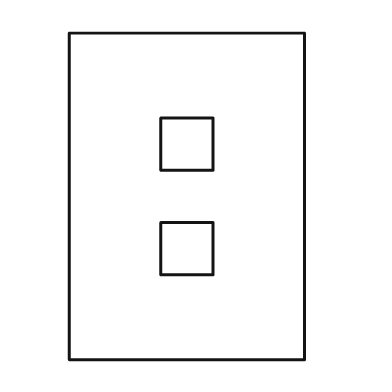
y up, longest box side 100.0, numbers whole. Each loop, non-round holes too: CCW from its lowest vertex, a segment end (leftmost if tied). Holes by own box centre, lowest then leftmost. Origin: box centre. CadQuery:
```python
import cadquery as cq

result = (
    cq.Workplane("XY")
    .moveTo(-36.0, -50.0)
    .lineTo(36.0, -50.0)
    .lineTo(36.0, 50.0)
    .lineTo(-36.0, 50.0)
    .close()
    .moveTo(-8.0, -24.0)
    .lineTo(8.0, -24.0)
    .lineTo(8.0, -8.0)
    .lineTo(-8.0, -8.0)
    .close()
    .moveTo(-8.0, 8.0)
    .lineTo(8.0, 8.0)
    .lineTo(8.0, 24.0)
    .lineTo(-8.0, 24.0)
    .close()
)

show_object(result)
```